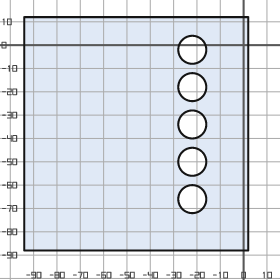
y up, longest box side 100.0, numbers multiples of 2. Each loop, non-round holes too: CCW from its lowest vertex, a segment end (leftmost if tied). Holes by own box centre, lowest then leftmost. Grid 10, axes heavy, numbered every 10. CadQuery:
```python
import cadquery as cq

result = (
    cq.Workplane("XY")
    .moveTo(-94.0, -88.0)
    .lineTo(2.0, -88.0)
    .lineTo(2.0, 12.0)
    .lineTo(-94.0, 12.0)
    .close()
    .moveTo(-22.0, -66.0)
    .circle(6.0)
    .moveTo(-22.0, -50.0)
    .circle(6.0)
    .moveTo(-22.0, -34.0)
    .circle(6.0)
    .moveTo(-22.0, -18.0)
    .circle(6.0)
    .moveTo(-22.0, -2.0)
    .circle(6.0)
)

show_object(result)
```